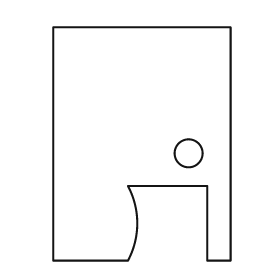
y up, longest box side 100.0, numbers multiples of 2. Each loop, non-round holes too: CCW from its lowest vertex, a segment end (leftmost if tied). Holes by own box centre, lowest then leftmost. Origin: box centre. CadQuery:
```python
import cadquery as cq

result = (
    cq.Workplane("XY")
    .moveTo(-38.0, -50.0)
    .lineTo(-6.0, -50.0)
    .threePointArc((-2.0, -34.0), (-6.0, -18.0))
    .lineTo(28.0, -18.0)
    .lineTo(28.0, -50.0)
    .lineTo(38.0, -50.0)
    .lineTo(38.0, 50.0)
    .lineTo(-38.0, 50.0)
    .close()
    .moveTo(20.0, -4.0)
    .circle(6.0)
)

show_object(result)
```